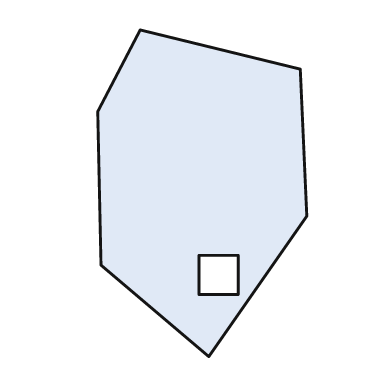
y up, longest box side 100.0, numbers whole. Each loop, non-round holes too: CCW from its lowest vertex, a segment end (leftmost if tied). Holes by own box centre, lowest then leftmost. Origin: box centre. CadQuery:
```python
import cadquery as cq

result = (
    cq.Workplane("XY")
    .moveTo(2.0, -50.0)
    .lineTo(32.0, -7.0)
    .lineTo(30.0, 38.0)
    .lineTo(-19.0, 50.0)
    .lineTo(-32.0, 25.0)
    .lineTo(-31.0, -22.0)
    .close()
    .moveTo(-1.0, -31.0)
    .lineTo(11.0, -31.0)
    .lineTo(11.0, -19.0)
    .lineTo(-1.0, -19.0)
    .close()
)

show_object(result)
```